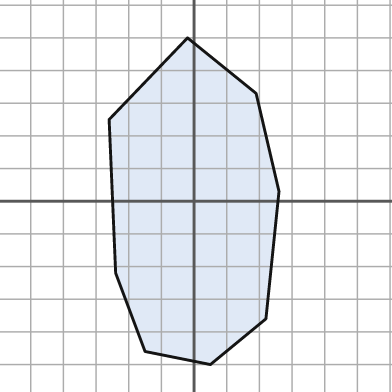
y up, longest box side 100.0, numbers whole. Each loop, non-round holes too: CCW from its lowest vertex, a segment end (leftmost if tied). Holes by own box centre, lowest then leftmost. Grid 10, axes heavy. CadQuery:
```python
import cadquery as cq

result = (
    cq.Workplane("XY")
    .moveTo(5.0, -50.0)
    .lineTo(22.0, -36.0)
    .lineTo(26.0, 3.0)
    .lineTo(19.0, 33.0)
    .lineTo(-2.0, 50.0)
    .lineTo(-26.0, 25.0)
    .lineTo(-24.0, -22.0)
    .lineTo(-15.0, -46.0)
    .close()
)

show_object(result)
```